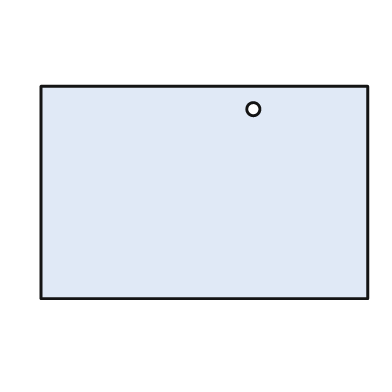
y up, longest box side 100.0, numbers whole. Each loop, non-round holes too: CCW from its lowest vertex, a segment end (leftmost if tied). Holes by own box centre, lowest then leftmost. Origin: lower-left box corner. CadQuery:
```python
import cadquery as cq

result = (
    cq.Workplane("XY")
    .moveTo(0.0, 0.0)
    .lineTo(100.0, 0.0)
    .lineTo(100.0, 65.0)
    .lineTo(0.0, 65.0)
    .close()
    .moveTo(65.0, 58.0)
    .circle(2.0)
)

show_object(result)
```